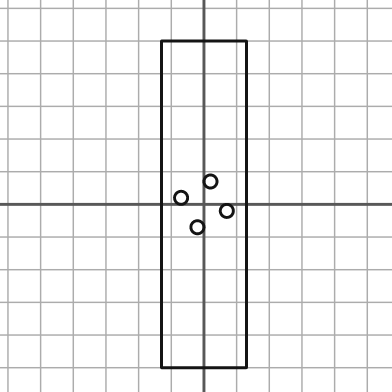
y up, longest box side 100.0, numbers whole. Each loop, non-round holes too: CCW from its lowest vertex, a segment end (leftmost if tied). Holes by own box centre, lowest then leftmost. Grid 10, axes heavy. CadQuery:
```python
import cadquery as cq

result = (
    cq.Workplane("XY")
    .moveTo(-13.0, -50.0)
    .lineTo(13.0, -50.0)
    .lineTo(13.0, 50.0)
    .lineTo(-13.0, 50.0)
    .close()
    .moveTo(-2.0, -7.0)
    .circle(2.0)
    .moveTo(7.0, -2.0)
    .circle(2.0)
    .moveTo(-7.0, 2.0)
    .circle(2.0)
    .moveTo(2.0, 7.0)
    .circle(2.0)
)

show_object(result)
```